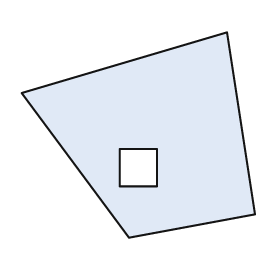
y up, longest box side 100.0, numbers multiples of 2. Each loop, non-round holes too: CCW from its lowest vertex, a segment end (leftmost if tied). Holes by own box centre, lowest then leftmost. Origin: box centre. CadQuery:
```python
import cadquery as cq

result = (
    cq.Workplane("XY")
    .moveTo(-4.0, -44.0)
    .lineTo(50.0, -34.0)
    .lineTo(38.0, 44.0)
    .lineTo(-50.0, 18.0)
    .close()
    .moveTo(-8.0, -22.0)
    .lineTo(8.0, -22.0)
    .lineTo(8.0, -6.0)
    .lineTo(-8.0, -6.0)
    .close()
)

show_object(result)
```